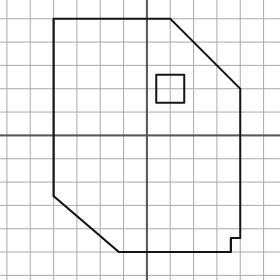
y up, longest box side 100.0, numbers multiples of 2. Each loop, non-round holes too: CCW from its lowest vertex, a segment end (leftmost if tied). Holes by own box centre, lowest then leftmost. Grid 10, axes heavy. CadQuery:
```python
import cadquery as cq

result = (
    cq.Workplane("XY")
    .moveTo(-12.0, -50.0)
    .lineTo(36.0, -50.0)
    .lineTo(36.0, -44.0)
    .lineTo(40.0, -44.0)
    .lineTo(40.0, 20.0)
    .lineTo(10.0, 50.0)
    .lineTo(-40.0, 50.0)
    .lineTo(-40.0, -26.0)
    .close()
    .moveTo(4.0, 14.0)
    .lineTo(16.0, 14.0)
    .lineTo(16.0, 26.0)
    .lineTo(4.0, 26.0)
    .close()
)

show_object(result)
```